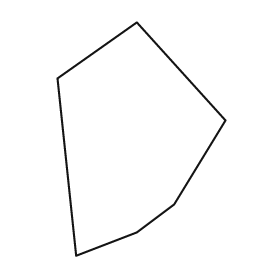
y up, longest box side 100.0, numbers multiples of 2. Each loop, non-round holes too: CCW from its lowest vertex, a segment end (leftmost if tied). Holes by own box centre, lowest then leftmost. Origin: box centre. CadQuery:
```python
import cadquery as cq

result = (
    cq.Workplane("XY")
    .moveTo(-28.0, -50.0)
    .lineTo(-2.0, -40.0)
    .lineTo(14.0, -28.0)
    .lineTo(36.0, 8.0)
    .lineTo(-2.0, 50.0)
    .lineTo(-36.0, 26.0)
    .close()
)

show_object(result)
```